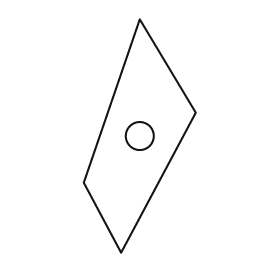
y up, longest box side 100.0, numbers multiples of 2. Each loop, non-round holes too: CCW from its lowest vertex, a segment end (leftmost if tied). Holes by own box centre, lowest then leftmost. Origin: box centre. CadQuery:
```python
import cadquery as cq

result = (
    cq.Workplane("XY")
    .moveTo(-8.0, -50.0)
    .lineTo(24.0, 10.0)
    .lineTo(0.0, 50.0)
    .lineTo(-24.0, -20.0)
    .close()
    .moveTo(0.0, 0.0)
    .circle(6.0)
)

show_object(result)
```